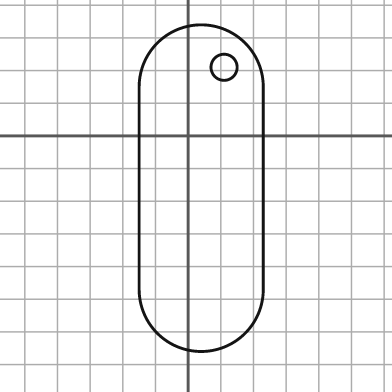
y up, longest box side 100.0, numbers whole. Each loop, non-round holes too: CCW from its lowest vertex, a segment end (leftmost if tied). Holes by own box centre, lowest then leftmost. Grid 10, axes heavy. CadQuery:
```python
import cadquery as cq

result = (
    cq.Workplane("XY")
    .moveTo(-15.0, -47.0)
    .threePointArc((4.0, -66.0), (23.0, -47.0))
    .lineTo(23.0, 15.0)
    .threePointArc((4.0, 34.0), (-15.0, 15.0))
    .close()
    .moveTo(11.0, 21.0)
    .circle(4.0)
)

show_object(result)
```